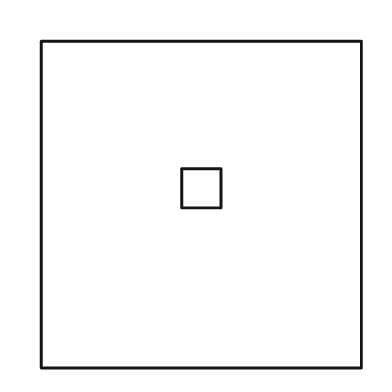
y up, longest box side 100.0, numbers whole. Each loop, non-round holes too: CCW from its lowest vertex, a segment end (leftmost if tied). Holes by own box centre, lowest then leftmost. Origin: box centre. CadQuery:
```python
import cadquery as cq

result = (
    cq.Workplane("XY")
    .moveTo(-49.0, -50.0)
    .lineTo(49.0, -50.0)
    .lineTo(49.0, 50.0)
    .lineTo(-49.0, 50.0)
    .close()
    .moveTo(-6.0, -1.0)
    .lineTo(6.0, -1.0)
    .lineTo(6.0, 11.0)
    .lineTo(-6.0, 11.0)
    .close()
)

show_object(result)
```